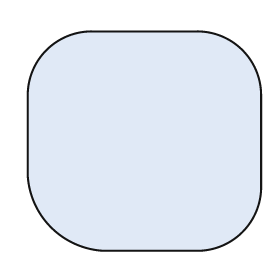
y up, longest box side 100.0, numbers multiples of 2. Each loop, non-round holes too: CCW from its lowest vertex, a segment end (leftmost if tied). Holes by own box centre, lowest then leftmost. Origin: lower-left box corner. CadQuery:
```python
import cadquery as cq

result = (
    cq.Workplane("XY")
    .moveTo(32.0, 0.0)
    .lineTo(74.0, 0.0)
    .threePointArc((92.0, 8.0), (100.0, 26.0))
    .lineTo(100.0, 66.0)
    .threePointArc((92.0, 86.0), (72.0, 94.0))
    .lineTo(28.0, 94.0)
    .threePointArc((8.0, 86.0), (0.0, 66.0))
    .lineTo(0.0, 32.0)
    .threePointArc((10.0, 10.0), (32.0, 0.0))
    .close()
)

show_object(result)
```